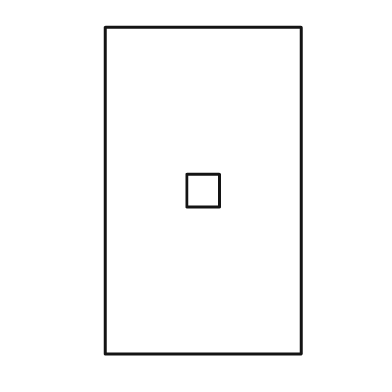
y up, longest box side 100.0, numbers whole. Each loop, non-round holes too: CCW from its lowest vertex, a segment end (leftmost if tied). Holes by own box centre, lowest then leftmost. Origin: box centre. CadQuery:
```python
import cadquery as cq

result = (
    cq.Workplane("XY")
    .moveTo(-30.0, -50.0)
    .lineTo(30.0, -50.0)
    .lineTo(30.0, 50.0)
    .lineTo(-30.0, 50.0)
    .close()
    .moveTo(-5.0, -5.0)
    .lineTo(5.0, -5.0)
    .lineTo(5.0, 5.0)
    .lineTo(-5.0, 5.0)
    .close()
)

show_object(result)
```